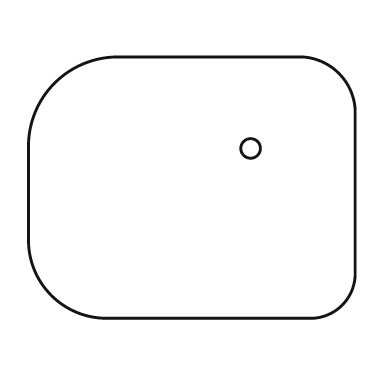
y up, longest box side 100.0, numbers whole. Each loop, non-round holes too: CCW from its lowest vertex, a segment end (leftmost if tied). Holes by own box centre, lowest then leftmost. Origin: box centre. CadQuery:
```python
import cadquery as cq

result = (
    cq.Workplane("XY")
    .moveTo(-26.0, -40.0)
    .lineTo(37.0, -40.0)
    .threePointArc((46.0, -36.0), (50.0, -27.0))
    .lineTo(50.0, 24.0)
    .threePointArc((45.0, 35.0), (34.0, 40.0))
    .lineTo(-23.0, 40.0)
    .threePointArc((-42.0, 32.0), (-50.0, 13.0))
    .lineTo(-50.0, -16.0)
    .threePointArc((-43.0, -33.0), (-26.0, -40.0))
    .close()
    .moveTo(18.0, 12.0)
    .circle(3.0)
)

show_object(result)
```